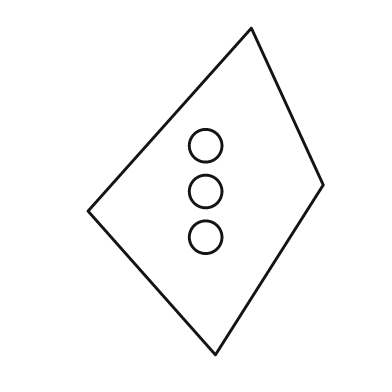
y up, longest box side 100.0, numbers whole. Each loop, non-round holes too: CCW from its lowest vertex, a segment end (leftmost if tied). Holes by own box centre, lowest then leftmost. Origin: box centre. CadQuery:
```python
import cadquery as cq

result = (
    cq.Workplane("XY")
    .moveTo(3.0, -50.0)
    .lineTo(36.0, 2.0)
    .lineTo(14.0, 50.0)
    .lineTo(-36.0, -6.0)
    .close()
    .moveTo(0.0, -14.0)
    .circle(5.0)
    .moveTo(0.0, 0.0)
    .circle(5.0)
    .moveTo(0.0, 14.0)
    .circle(5.0)
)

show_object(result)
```